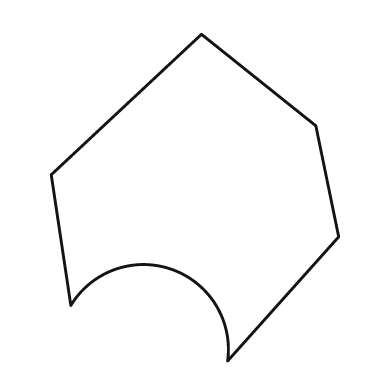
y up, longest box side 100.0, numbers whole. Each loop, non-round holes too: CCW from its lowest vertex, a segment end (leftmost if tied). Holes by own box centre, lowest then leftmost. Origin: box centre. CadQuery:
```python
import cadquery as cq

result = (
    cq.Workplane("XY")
    .moveTo(10.0, -50.0)
    .lineTo(44.0, -12.0)
    .lineTo(37.0, 22.0)
    .lineTo(2.0, 50.0)
    .lineTo(-44.0, 7.0)
    .lineTo(-38.0, -33.0)
    .threePointArc((-7.0, -22.0), (10.0, -50.0))
    .close()
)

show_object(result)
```